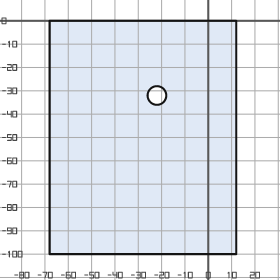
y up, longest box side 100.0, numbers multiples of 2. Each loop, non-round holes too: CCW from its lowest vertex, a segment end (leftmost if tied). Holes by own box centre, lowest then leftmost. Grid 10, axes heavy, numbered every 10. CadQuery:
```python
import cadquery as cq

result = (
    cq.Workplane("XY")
    .moveTo(-68.0, -100.0)
    .lineTo(12.0, -100.0)
    .lineTo(12.0, 0.0)
    .lineTo(-68.0, 0.0)
    .close()
    .moveTo(-22.0, -32.0)
    .circle(4.0)
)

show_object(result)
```